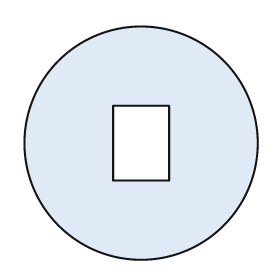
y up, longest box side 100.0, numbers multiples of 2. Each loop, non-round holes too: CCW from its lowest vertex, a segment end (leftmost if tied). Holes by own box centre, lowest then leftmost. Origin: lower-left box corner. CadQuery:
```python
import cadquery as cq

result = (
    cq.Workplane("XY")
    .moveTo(50.0, 50.0)
    .circle(50.0)
    .moveTo(38.0, 34.0)
    .lineTo(62.0, 34.0)
    .lineTo(62.0, 66.0)
    .lineTo(38.0, 66.0)
    .close()
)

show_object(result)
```